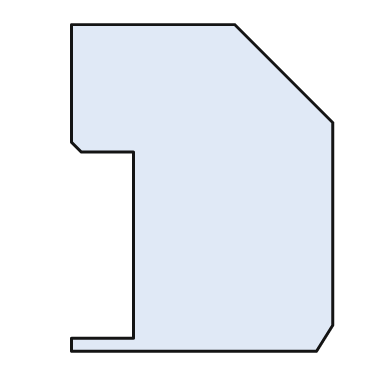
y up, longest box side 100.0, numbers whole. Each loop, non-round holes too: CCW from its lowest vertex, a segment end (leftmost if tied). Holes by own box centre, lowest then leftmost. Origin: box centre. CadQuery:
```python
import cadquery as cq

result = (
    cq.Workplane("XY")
    .moveTo(-40.0, -50.0)
    .lineTo(35.0, -50.0)
    .lineTo(40.0, -42.0)
    .lineTo(40.0, 20.0)
    .lineTo(10.0, 50.0)
    .lineTo(-40.0, 50.0)
    .lineTo(-40.0, 14.0)
    .lineTo(-37.0, 11.0)
    .lineTo(-21.0, 11.0)
    .lineTo(-21.0, -46.0)
    .lineTo(-40.0, -46.0)
    .close()
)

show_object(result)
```